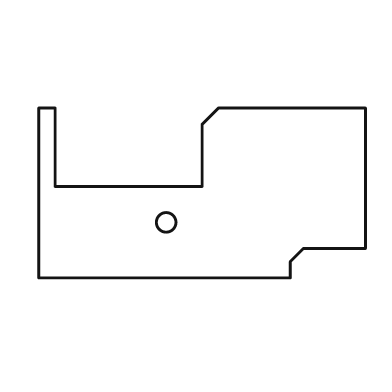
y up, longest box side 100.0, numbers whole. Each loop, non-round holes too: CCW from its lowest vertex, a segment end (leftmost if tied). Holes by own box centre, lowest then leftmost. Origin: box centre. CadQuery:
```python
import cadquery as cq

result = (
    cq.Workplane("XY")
    .moveTo(-50.0, -26.0)
    .lineTo(27.0, -26.0)
    .lineTo(27.0, -21.0)
    .lineTo(31.0, -17.0)
    .lineTo(50.0, -17.0)
    .lineTo(50.0, 26.0)
    .lineTo(5.0, 26.0)
    .lineTo(0.0, 21.0)
    .lineTo(0.0, 2.0)
    .lineTo(-45.0, 2.0)
    .lineTo(-45.0, 26.0)
    .lineTo(-50.0, 26.0)
    .close()
    .moveTo(-11.0, -9.0)
    .circle(3.0)
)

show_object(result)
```